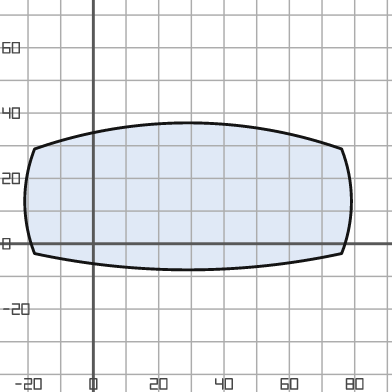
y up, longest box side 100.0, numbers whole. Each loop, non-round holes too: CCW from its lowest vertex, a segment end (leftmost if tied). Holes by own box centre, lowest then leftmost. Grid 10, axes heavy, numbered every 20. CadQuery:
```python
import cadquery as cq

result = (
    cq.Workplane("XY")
    .moveTo(-18.0, -3.0)
    .threePointArc((29.0, -8.0), (76.0, -3.0))
    .threePointArc((79.0, 13.0), (76.0, 29.0))
    .threePointArc((29.0, 37.0), (-18.0, 29.0))
    .threePointArc((-21.0, 13.0), (-18.0, -3.0))
    .close()
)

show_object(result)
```